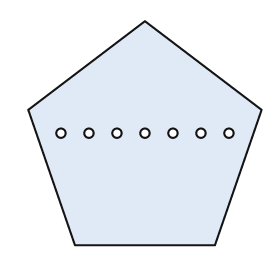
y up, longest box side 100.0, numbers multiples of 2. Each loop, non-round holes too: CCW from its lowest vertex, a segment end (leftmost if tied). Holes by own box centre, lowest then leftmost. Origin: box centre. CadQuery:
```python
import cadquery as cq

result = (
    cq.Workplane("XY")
    .moveTo(-30.0, -48.0)
    .lineTo(30.0, -48.0)
    .lineTo(50.0, 10.0)
    .lineTo(0.0, 48.0)
    .lineTo(-50.0, 10.0)
    .close()
    .moveTo(-36.0, 0.0)
    .circle(2.0)
    .moveTo(-24.0, 0.0)
    .circle(2.0)
    .moveTo(-12.0, 0.0)
    .circle(2.0)
    .moveTo(0.0, 0.0)
    .circle(2.0)
    .moveTo(12.0, 0.0)
    .circle(2.0)
    .moveTo(24.0, 0.0)
    .circle(2.0)
    .moveTo(36.0, 0.0)
    .circle(2.0)
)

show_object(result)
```